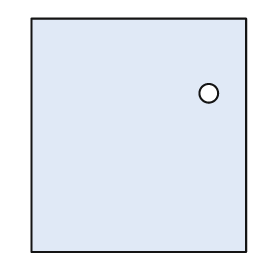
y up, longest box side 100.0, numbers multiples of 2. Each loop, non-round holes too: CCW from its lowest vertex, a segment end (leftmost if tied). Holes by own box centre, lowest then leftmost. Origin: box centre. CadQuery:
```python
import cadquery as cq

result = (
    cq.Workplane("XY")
    .moveTo(-46.0, -50.0)
    .lineTo(46.0, -50.0)
    .lineTo(46.0, 50.0)
    .lineTo(-46.0, 50.0)
    .close()
    .moveTo(30.0, 18.0)
    .circle(4.0)
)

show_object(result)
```